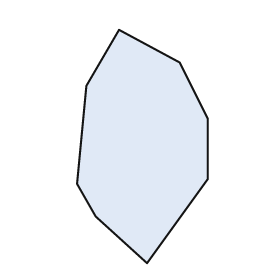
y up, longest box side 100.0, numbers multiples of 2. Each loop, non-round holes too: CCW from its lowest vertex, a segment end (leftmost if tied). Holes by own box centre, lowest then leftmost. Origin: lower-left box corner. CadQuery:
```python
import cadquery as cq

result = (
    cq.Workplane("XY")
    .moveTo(30.0, 0.0)
    .lineTo(56.0, 36.0)
    .lineTo(56.0, 62.0)
    .lineTo(44.0, 86.0)
    .lineTo(18.0, 100.0)
    .lineTo(4.0, 76.0)
    .lineTo(0.0, 34.0)
    .lineTo(8.0, 20.0)
    .close()
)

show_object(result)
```